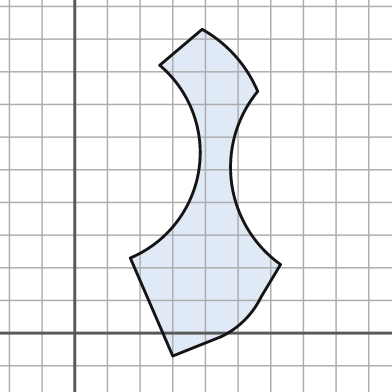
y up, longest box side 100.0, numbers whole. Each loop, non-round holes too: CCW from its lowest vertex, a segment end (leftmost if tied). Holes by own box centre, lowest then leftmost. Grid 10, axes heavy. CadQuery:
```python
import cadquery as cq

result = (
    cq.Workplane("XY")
    .moveTo(30.0, -7.0)
    .lineTo(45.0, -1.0)
    .threePointArc((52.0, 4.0), (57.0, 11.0))
    .lineTo(63.0, 21.0)
    .threePointArc((48.0, 46.0), (56.0, 74.0))
    .threePointArc((49.0, 85.0), (39.0, 93.0))
    .lineTo(26.0, 82.0)
    .threePointArc((38.0, 50.0), (17.0, 23.0))
    .close()
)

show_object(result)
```